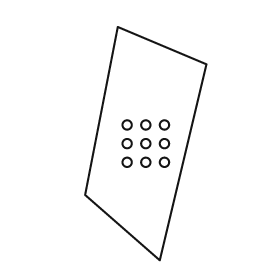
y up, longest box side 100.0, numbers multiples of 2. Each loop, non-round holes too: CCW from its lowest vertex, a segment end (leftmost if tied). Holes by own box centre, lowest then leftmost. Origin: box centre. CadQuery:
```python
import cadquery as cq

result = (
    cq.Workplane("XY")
    .moveTo(6.0, -50.0)
    .lineTo(26.0, 34.0)
    .lineTo(-12.0, 50.0)
    .lineTo(-26.0, -22.0)
    .close()
    .moveTo(-8.0, -8.0)
    .circle(2.0)
    .moveTo(0.0, -8.0)
    .circle(2.0)
    .moveTo(8.0, -8.0)
    .circle(2.0)
    .moveTo(-8.0, 0.0)
    .circle(2.0)
    .moveTo(0.0, 0.0)
    .circle(2.0)
    .moveTo(8.0, 0.0)
    .circle(2.0)
    .moveTo(-8.0, 8.0)
    .circle(2.0)
    .moveTo(0.0, 8.0)
    .circle(2.0)
    .moveTo(8.0, 8.0)
    .circle(2.0)
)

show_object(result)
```